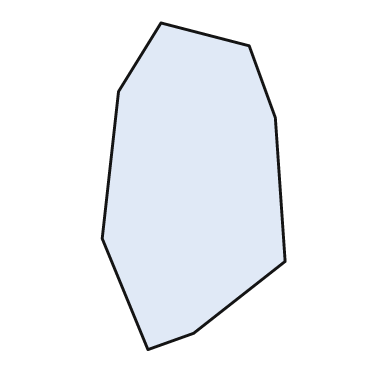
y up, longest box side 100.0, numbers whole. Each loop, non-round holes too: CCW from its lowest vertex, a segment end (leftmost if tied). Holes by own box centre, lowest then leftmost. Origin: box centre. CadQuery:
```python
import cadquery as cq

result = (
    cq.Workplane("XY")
    .moveTo(-14.0, -50.0)
    .lineTo(0.0, -45.0)
    .lineTo(28.0, -23.0)
    .lineTo(25.0, 21.0)
    .lineTo(17.0, 43.0)
    .lineTo(-10.0, 50.0)
    .lineTo(-23.0, 29.0)
    .lineTo(-28.0, -16.0)
    .close()
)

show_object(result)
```